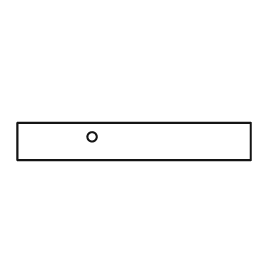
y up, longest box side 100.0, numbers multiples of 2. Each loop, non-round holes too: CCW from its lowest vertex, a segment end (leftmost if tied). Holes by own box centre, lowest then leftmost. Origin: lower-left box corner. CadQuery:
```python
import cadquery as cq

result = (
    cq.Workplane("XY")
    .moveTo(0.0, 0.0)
    .lineTo(100.0, 0.0)
    .lineTo(100.0, 16.0)
    .lineTo(0.0, 16.0)
    .close()
    .moveTo(32.0, 10.0)
    .circle(2.0)
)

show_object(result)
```